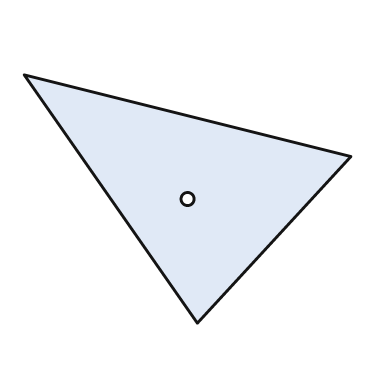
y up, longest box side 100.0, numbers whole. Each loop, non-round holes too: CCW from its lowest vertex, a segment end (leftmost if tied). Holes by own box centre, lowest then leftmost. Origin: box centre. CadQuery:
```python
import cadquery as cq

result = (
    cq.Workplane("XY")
    .moveTo(3.0, -38.0)
    .lineTo(50.0, 13.0)
    .lineTo(-50.0, 38.0)
    .close()
    .moveTo(0.0, 0.0)
    .circle(2.0)
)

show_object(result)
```